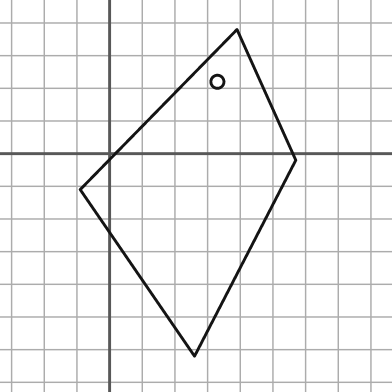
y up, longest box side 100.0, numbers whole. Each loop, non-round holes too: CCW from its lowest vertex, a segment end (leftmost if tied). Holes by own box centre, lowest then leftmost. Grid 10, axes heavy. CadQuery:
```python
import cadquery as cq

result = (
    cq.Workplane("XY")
    .moveTo(26.0, -62.0)
    .lineTo(57.0, -2.0)
    .lineTo(39.0, 38.0)
    .lineTo(-9.0, -11.0)
    .close()
    .moveTo(33.0, 22.0)
    .circle(2.0)
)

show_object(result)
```